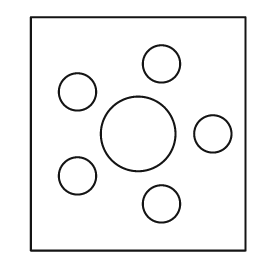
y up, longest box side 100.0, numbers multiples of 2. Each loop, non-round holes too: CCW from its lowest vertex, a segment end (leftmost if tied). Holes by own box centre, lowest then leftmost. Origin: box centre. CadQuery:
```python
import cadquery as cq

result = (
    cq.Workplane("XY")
    .moveTo(-46.0, -50.0)
    .lineTo(46.0, -50.0)
    .lineTo(46.0, 50.0)
    .lineTo(-46.0, 50.0)
    .close()
    .moveTo(10.0, -30.0)
    .circle(8.0)
    .moveTo(-26.0, -18.0)
    .circle(8.0)
    .moveTo(0.0, 0.0)
    .circle(16.0)
    .moveTo(32.0, 0.0)
    .circle(8.0)
    .moveTo(-26.0, 18.0)
    .circle(8.0)
    .moveTo(10.0, 30.0)
    .circle(8.0)
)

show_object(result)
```